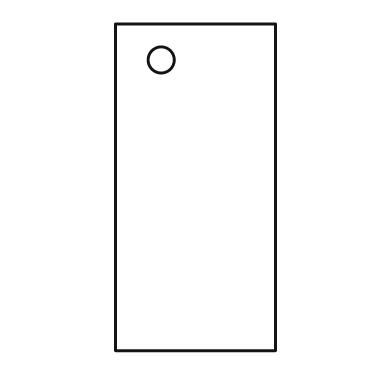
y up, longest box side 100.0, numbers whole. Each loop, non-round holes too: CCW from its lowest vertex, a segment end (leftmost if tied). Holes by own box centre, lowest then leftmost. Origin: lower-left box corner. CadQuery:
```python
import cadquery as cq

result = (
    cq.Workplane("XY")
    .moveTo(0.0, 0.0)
    .lineTo(49.0, 0.0)
    .lineTo(49.0, 100.0)
    .lineTo(0.0, 100.0)
    .close()
    .moveTo(14.0, 89.0)
    .circle(4.0)
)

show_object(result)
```